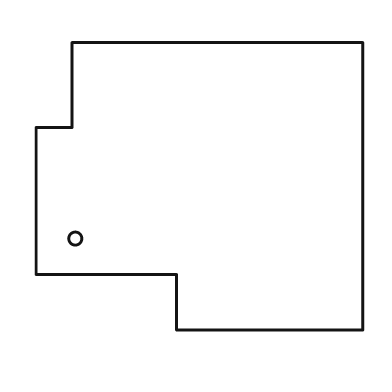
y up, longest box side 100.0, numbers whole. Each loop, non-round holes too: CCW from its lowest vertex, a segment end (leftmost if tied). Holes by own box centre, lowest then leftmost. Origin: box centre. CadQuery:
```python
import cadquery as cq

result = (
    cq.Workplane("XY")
    .moveTo(-7.0, -44.0)
    .lineTo(50.0, -44.0)
    .lineTo(50.0, 44.0)
    .lineTo(-39.0, 44.0)
    .lineTo(-39.0, 18.0)
    .lineTo(-50.0, 18.0)
    .lineTo(-50.0, -27.0)
    .lineTo(-7.0, -27.0)
    .close()
    .moveTo(-38.0, -16.0)
    .circle(2.0)
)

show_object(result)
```